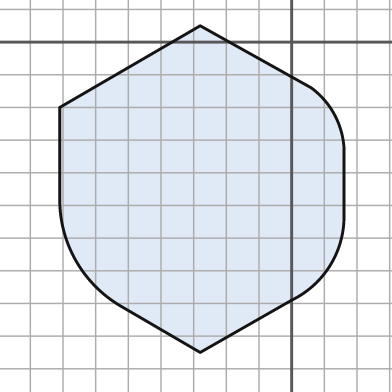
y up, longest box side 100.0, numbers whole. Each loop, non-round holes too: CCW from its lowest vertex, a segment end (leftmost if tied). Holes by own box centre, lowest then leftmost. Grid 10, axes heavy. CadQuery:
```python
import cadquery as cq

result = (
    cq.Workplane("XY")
    .moveTo(-28.0, -95.0)
    .lineTo(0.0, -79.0)
    .threePointArc((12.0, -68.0), (16.0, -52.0))
    .lineTo(16.0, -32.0)
    .threePointArc((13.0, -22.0), (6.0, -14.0))
    .lineTo(-28.0, 5.0)
    .lineTo(-71.0, -20.0)
    .lineTo(-71.0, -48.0)
    .threePointArc((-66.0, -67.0), (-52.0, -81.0))
    .close()
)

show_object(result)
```